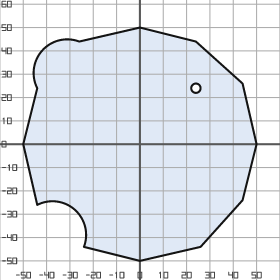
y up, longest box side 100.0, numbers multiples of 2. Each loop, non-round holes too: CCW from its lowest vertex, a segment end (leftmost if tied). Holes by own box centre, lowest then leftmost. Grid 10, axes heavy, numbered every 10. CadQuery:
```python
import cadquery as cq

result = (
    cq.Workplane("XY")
    .moveTo(0.0, -50.0)
    .lineTo(26.0, -44.0)
    .lineTo(44.0, -24.0)
    .lineTo(50.0, 0.0)
    .lineTo(44.0, 26.0)
    .lineTo(24.0, 44.0)
    .lineTo(0.0, 50.0)
    .lineTo(-26.0, 44.0)
    .threePointArc((-42.0, 40.0), (-44.0, 24.0))
    .lineTo(-50.0, 0.0)
    .lineTo(-44.0, -26.0)
    .threePointArc((-28.0, -28.0), (-24.0, -44.0))
    .close()
    .moveTo(24.0, 24.0)
    .circle(2.0)
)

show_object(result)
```